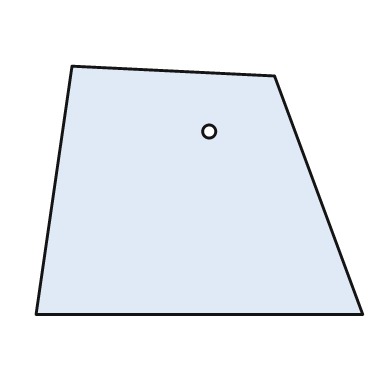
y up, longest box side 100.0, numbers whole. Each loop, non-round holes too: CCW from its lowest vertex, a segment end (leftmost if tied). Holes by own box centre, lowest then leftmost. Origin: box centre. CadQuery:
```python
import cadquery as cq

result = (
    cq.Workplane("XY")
    .moveTo(-50.0, -38.0)
    .lineTo(50.0, -38.0)
    .lineTo(23.0, 35.0)
    .lineTo(-39.0, 38.0)
    .close()
    .moveTo(3.0, 18.0)
    .circle(2.0)
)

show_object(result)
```